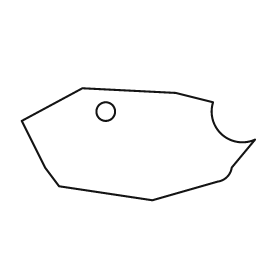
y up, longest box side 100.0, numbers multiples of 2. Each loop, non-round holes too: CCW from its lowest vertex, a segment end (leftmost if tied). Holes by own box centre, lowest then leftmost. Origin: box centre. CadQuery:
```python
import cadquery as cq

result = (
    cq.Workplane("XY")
    .moveTo(6.0, -24.0)
    .lineTo(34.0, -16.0)
    .threePointArc((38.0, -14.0), (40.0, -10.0))
    .lineTo(50.0, 2.0)
    .threePointArc((36.0, 4.0), (32.0, 18.0))
    .lineTo(16.0, 22.0)
    .lineTo(-24.0, 24.0)
    .lineTo(-50.0, 10.0)
    .lineTo(-40.0, -10.0)
    .lineTo(-34.0, -18.0)
    .close()
    .moveTo(-14.0, 14.0)
    .circle(4.0)
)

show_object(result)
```